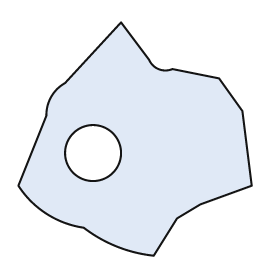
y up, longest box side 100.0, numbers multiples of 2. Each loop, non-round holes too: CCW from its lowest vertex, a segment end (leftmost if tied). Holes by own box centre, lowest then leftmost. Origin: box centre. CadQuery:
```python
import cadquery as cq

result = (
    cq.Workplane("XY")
    .moveTo(8.0, -50.0)
    .lineTo(18.0, -34.0)
    .lineTo(28.0, -28.0)
    .lineTo(50.0, -20.0)
    .lineTo(46.0, 12.0)
    .lineTo(36.0, 26.0)
    .lineTo(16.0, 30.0)
    .threePointArc((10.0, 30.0), (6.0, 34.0))
    .lineTo(-6.0, 50.0)
    .lineTo(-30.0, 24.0)
    .threePointArc((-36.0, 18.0), (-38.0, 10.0))
    .lineTo(-50.0, -20.0)
    .threePointArc((-38.0, -32.0), (-22.0, -38.0))
    .threePointArc((-8.0, -46.0), (8.0, -50.0))
    .close()
    .moveTo(-18.0, -6.0)
    .circle(12.0)
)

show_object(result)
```